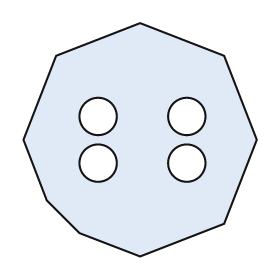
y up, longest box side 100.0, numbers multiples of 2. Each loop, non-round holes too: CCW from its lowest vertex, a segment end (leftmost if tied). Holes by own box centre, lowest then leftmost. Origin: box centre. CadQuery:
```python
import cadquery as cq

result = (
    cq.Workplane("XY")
    .moveTo(0.0, -50.0)
    .lineTo(36.0, -36.0)
    .lineTo(50.0, 0.0)
    .lineTo(36.0, 36.0)
    .lineTo(0.0, 50.0)
    .lineTo(-36.0, 36.0)
    .lineTo(-50.0, 0.0)
    .lineTo(-40.0, -26.0)
    .lineTo(-26.0, -40.0)
    .close()
    .moveTo(-18.0, -10.0)
    .circle(8.0)
    .moveTo(20.0, -10.0)
    .circle(8.0)
    .moveTo(-18.0, 10.0)
    .circle(8.0)
    .moveTo(20.0, 10.0)
    .circle(8.0)
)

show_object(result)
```